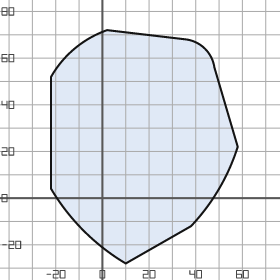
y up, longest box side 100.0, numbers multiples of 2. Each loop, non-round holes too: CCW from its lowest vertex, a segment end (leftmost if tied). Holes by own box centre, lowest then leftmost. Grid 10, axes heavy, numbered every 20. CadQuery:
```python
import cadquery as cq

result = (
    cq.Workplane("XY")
    .moveTo(10.0, -28.0)
    .lineTo(38.0, -12.0)
    .threePointArc((50.0, 4.0), (58.0, 22.0))
    .lineTo(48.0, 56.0)
    .threePointArc((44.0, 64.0), (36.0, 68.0))
    .lineTo(2.0, 72.0)
    .threePointArc((-12.0, 64.0), (-22.0, 52.0))
    .lineTo(-22.0, 4.0)
    .threePointArc((-8.0, -14.0), (10.0, -28.0))
    .close()
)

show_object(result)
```